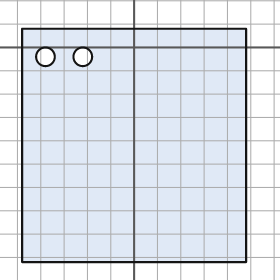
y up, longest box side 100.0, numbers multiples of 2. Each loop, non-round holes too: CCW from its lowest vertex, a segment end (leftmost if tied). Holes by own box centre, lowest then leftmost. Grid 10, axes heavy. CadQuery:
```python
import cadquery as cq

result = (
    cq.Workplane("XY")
    .moveTo(-48.0, -92.0)
    .lineTo(48.0, -92.0)
    .lineTo(48.0, 8.0)
    .lineTo(-48.0, 8.0)
    .close()
    .moveTo(-38.0, -4.0)
    .circle(4.0)
    .moveTo(-22.0, -4.0)
    .circle(4.0)
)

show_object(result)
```